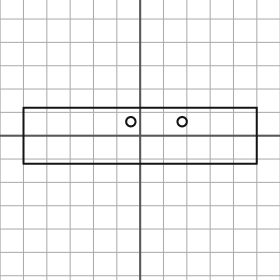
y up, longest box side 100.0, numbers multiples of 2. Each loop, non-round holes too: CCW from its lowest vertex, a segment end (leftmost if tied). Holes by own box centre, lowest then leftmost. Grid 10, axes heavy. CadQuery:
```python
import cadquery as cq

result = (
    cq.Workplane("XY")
    .moveTo(-50.0, -12.0)
    .lineTo(50.0, -12.0)
    .lineTo(50.0, 12.0)
    .lineTo(-50.0, 12.0)
    .close()
    .moveTo(-4.0, 6.0)
    .circle(2.0)
    .moveTo(18.0, 6.0)
    .circle(2.0)
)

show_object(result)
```